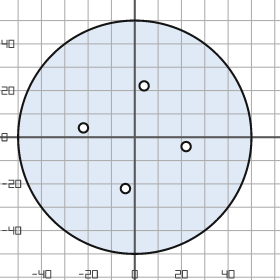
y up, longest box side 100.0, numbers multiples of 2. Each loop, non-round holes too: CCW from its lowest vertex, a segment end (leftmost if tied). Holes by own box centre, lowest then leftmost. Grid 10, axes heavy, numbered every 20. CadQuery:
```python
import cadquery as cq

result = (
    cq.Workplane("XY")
    .moveTo(0.0, 0.0)
    .circle(50.0)
    .moveTo(-4.0, -22.0)
    .circle(2.0)
    .moveTo(22.0, -4.0)
    .circle(2.0)
    .moveTo(-22.0, 4.0)
    .circle(2.0)
    .moveTo(4.0, 22.0)
    .circle(2.0)
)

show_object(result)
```